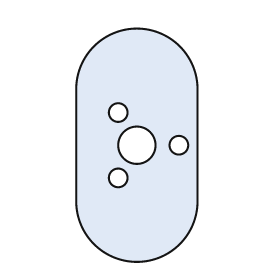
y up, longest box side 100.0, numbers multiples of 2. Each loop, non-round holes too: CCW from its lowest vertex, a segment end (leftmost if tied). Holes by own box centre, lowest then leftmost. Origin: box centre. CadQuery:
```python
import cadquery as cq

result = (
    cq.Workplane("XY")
    .moveTo(-26.0, -24.0)
    .threePointArc((0.0, -50.0), (26.0, -24.0))
    .lineTo(26.0, 24.0)
    .threePointArc((0.0, 50.0), (-26.0, 24.0))
    .close()
    .moveTo(-8.0, -14.0)
    .circle(4.0)
    .moveTo(0.0, 0.0)
    .circle(8.0)
    .moveTo(18.0, 0.0)
    .circle(4.0)
    .moveTo(-8.0, 14.0)
    .circle(4.0)
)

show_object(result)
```